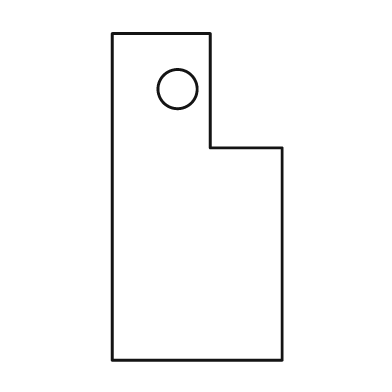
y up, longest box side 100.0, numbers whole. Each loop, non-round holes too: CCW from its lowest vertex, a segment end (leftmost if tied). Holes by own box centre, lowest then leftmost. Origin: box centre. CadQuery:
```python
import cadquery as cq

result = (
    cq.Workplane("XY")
    .moveTo(-26.0, -50.0)
    .lineTo(26.0, -50.0)
    .lineTo(26.0, 15.0)
    .lineTo(4.0, 15.0)
    .lineTo(4.0, 50.0)
    .lineTo(-26.0, 50.0)
    .close()
    .moveTo(-6.0, 33.0)
    .circle(6.0)
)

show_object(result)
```